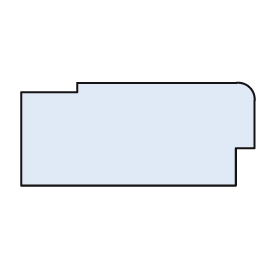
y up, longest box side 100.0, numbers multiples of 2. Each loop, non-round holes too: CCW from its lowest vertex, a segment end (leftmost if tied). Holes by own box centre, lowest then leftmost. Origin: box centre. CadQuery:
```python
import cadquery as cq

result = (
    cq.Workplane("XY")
    .moveTo(-50.0, -22.0)
    .lineTo(42.0, -22.0)
    .lineTo(42.0, -6.0)
    .lineTo(50.0, -6.0)
    .lineTo(50.0, 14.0)
    .threePointArc((48.0, 20.0), (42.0, 22.0))
    .lineTo(-26.0, 22.0)
    .lineTo(-26.0, 18.0)
    .lineTo(-50.0, 18.0)
    .close()
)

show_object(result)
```